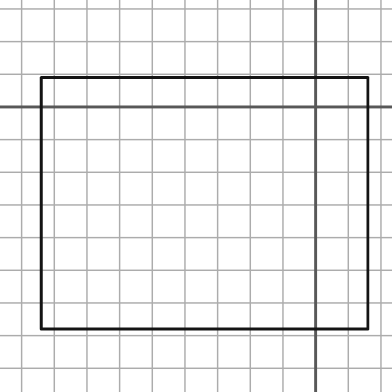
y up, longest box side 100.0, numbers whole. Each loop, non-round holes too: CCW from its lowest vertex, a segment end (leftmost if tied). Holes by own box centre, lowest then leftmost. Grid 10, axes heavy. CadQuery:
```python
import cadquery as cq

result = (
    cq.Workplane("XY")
    .moveTo(-84.0, -68.0)
    .lineTo(16.0, -68.0)
    .lineTo(16.0, 9.0)
    .lineTo(-84.0, 9.0)
    .close()
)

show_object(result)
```